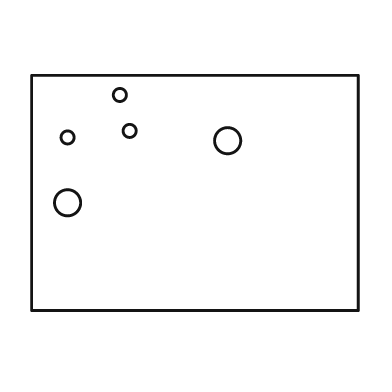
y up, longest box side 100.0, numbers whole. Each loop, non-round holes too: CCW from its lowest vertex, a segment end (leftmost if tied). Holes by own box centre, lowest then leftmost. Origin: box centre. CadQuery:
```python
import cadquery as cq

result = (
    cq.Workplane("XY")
    .moveTo(-50.0, -36.0)
    .lineTo(50.0, -36.0)
    .lineTo(50.0, 36.0)
    .lineTo(-50.0, 36.0)
    .close()
    .moveTo(-39.0, -3.0)
    .circle(4.0)
    .moveTo(10.0, 16.0)
    .circle(4.0)
    .moveTo(-39.0, 17.0)
    .circle(2.0)
    .moveTo(-20.0, 19.0)
    .circle(2.0)
    .moveTo(-23.0, 30.0)
    .circle(2.0)
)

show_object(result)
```